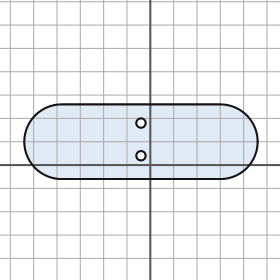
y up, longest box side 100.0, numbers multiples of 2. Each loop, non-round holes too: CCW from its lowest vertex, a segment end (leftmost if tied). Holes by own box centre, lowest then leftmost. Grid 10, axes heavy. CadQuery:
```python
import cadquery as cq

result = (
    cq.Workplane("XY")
    .moveTo(-38.0, -6.0)
    .lineTo(30.0, -6.0)
    .threePointArc((46.0, 10.0), (30.0, 26.0))
    .lineTo(-38.0, 26.0)
    .threePointArc((-54.0, 10.0), (-38.0, -6.0))
    .close()
    .moveTo(-4.0, 4.0)
    .circle(2.0)
    .moveTo(-4.0, 18.0)
    .circle(2.0)
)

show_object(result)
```